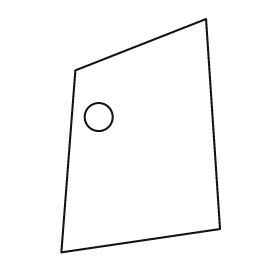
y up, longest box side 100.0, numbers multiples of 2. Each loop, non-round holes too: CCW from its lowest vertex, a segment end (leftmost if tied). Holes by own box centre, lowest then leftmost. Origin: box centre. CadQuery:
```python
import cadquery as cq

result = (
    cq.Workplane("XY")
    .moveTo(-34.0, -50.0)
    .lineTo(34.0, -40.0)
    .lineTo(28.0, 50.0)
    .lineTo(-28.0, 28.0)
    .close()
    .moveTo(-18.0, 8.0)
    .circle(6.0)
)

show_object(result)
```